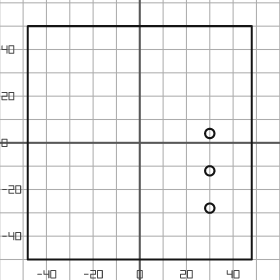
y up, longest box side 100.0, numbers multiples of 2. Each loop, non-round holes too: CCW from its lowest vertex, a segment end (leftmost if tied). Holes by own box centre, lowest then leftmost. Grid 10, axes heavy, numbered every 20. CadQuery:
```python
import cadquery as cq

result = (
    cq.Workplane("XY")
    .moveTo(-48.0, -50.0)
    .lineTo(48.0, -50.0)
    .lineTo(48.0, 50.0)
    .lineTo(-48.0, 50.0)
    .close()
    .moveTo(30.0, -28.0)
    .circle(2.0)
    .moveTo(30.0, -12.0)
    .circle(2.0)
    .moveTo(30.0, 4.0)
    .circle(2.0)
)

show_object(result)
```